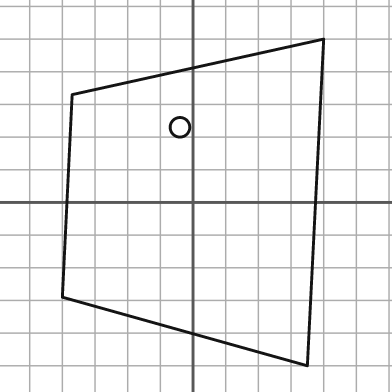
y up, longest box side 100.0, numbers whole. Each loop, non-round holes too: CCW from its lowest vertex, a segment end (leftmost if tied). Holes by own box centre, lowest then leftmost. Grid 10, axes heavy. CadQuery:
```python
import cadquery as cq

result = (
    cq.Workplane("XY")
    .moveTo(35.0, -50.0)
    .lineTo(40.0, 50.0)
    .lineTo(-37.0, 33.0)
    .lineTo(-40.0, -29.0)
    .close()
    .moveTo(-4.0, 23.0)
    .circle(3.0)
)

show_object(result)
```